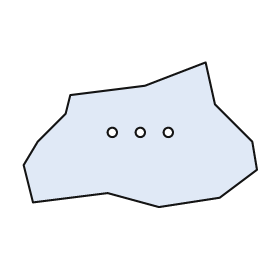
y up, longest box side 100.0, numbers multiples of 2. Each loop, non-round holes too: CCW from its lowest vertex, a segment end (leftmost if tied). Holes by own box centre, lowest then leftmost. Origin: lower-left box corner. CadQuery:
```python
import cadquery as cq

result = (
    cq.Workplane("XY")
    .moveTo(58.0, 0.0)
    .lineTo(84.0, 4.0)
    .lineTo(100.0, 16.0)
    .lineTo(98.0, 28.0)
    .lineTo(82.0, 44.0)
    .lineTo(78.0, 62.0)
    .lineTo(52.0, 52.0)
    .lineTo(20.0, 48.0)
    .lineTo(18.0, 40.0)
    .lineTo(6.0, 28.0)
    .lineTo(0.0, 18.0)
    .lineTo(4.0, 2.0)
    .lineTo(36.0, 6.0)
    .close()
    .moveTo(38.0, 32.0)
    .circle(2.0)
    .moveTo(50.0, 32.0)
    .circle(2.0)
    .moveTo(62.0, 32.0)
    .circle(2.0)
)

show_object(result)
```